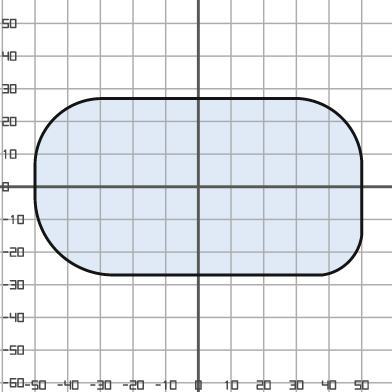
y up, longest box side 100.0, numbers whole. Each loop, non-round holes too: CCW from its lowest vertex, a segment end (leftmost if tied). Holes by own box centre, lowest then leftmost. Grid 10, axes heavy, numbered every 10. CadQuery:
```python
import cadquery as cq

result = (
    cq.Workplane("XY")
    .moveTo(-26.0, -27.0)
    .lineTo(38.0, -27.0)
    .threePointArc((46.0, -23.0), (50.0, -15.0))
    .lineTo(50.0, 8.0)
    .threePointArc((44.0, 21.0), (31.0, 27.0))
    .lineTo(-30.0, 27.0)
    .threePointArc((-44.0, 21.0), (-50.0, 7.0))
    .lineTo(-50.0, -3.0)
    .threePointArc((-43.0, -20.0), (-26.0, -27.0))
    .close()
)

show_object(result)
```